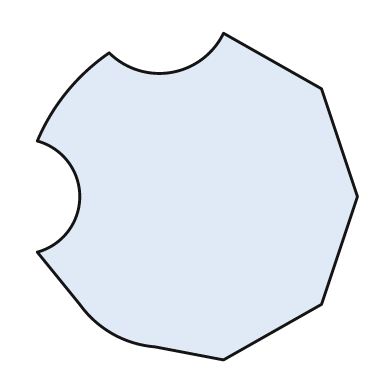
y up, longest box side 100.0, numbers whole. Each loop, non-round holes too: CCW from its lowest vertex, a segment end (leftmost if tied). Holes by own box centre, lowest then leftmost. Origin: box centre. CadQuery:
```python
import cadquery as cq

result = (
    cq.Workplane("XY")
    .moveTo(8.0, -50.0)
    .lineTo(38.0, -33.0)
    .lineTo(49.0, 0.0)
    .lineTo(38.0, 33.0)
    .lineTo(8.0, 50.0)
    .threePointArc((-8.0, 38.0), (-27.0, 44.0))
    .threePointArc((-40.0, 32.0), (-49.0, 17.0))
    .threePointArc((-36.0, 0.0), (-49.0, -17.0))
    .lineTo(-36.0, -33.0)
    .threePointArc((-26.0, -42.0), (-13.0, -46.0))
    .close()
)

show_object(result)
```